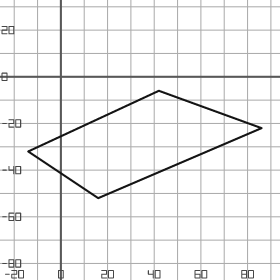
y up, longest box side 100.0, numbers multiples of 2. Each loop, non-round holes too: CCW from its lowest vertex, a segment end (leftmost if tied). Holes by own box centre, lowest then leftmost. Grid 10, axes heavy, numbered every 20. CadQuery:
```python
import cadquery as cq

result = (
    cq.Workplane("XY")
    .moveTo(16.0, -52.0)
    .lineTo(86.0, -22.0)
    .lineTo(42.0, -6.0)
    .lineTo(-14.0, -32.0)
    .close()
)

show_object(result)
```